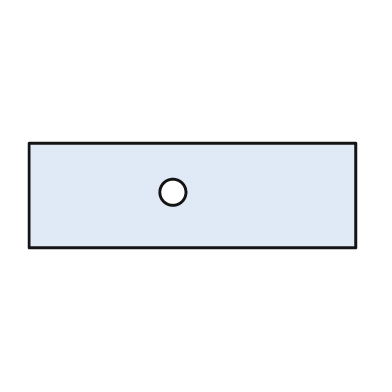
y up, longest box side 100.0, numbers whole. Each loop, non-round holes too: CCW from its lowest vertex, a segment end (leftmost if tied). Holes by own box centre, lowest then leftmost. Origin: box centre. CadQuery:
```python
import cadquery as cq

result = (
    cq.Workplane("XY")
    .moveTo(-50.0, -16.0)
    .lineTo(50.0, -16.0)
    .lineTo(50.0, 16.0)
    .lineTo(-50.0, 16.0)
    .close()
    .moveTo(-6.0, 1.0)
    .circle(4.0)
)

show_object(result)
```